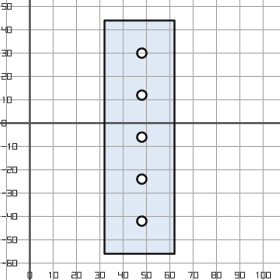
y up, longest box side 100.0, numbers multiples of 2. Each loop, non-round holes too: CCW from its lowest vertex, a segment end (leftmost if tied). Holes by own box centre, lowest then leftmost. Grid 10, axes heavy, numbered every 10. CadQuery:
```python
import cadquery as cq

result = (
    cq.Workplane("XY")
    .moveTo(32.0, -56.0)
    .lineTo(62.0, -56.0)
    .lineTo(62.0, 44.0)
    .lineTo(32.0, 44.0)
    .close()
    .moveTo(48.0, -42.0)
    .circle(2.0)
    .moveTo(48.0, -24.0)
    .circle(2.0)
    .moveTo(48.0, -6.0)
    .circle(2.0)
    .moveTo(48.0, 12.0)
    .circle(2.0)
    .moveTo(48.0, 30.0)
    .circle(2.0)
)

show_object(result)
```